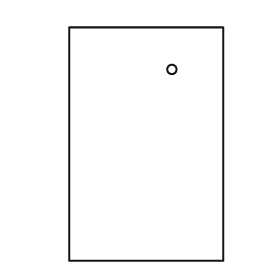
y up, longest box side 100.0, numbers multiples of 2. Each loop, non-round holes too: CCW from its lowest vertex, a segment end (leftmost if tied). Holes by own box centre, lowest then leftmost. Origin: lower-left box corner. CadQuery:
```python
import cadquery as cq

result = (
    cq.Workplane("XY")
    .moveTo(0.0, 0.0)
    .lineTo(66.0, 0.0)
    .lineTo(66.0, 100.0)
    .lineTo(0.0, 100.0)
    .close()
    .moveTo(44.0, 82.0)
    .circle(2.0)
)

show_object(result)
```